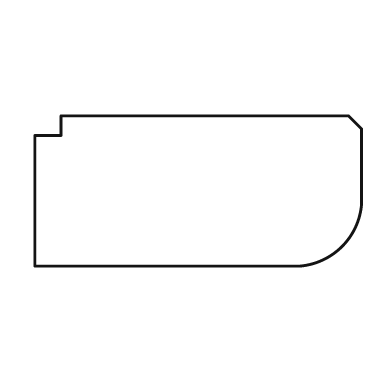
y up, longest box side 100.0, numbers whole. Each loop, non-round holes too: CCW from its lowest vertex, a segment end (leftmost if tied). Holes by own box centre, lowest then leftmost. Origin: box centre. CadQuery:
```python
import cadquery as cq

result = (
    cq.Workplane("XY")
    .moveTo(-50.0, -23.0)
    .lineTo(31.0, -23.0)
    .threePointArc((44.0, -17.0), (50.0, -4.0))
    .lineTo(50.0, 19.0)
    .lineTo(46.0, 23.0)
    .lineTo(-42.0, 23.0)
    .lineTo(-42.0, 17.0)
    .lineTo(-50.0, 17.0)
    .close()
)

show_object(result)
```